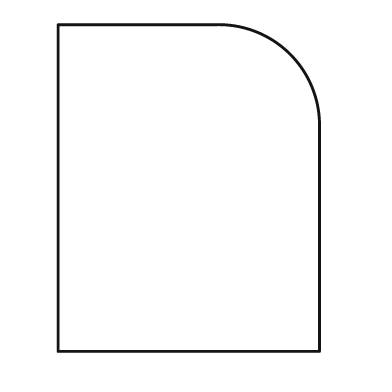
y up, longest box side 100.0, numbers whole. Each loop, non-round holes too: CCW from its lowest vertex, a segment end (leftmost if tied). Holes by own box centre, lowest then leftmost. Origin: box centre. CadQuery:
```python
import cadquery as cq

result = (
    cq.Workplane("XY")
    .moveTo(-40.0, -50.0)
    .lineTo(40.0, -50.0)
    .lineTo(40.0, 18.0)
    .threePointArc((31.0, 41.0), (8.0, 50.0))
    .lineTo(-40.0, 50.0)
    .close()
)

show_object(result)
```